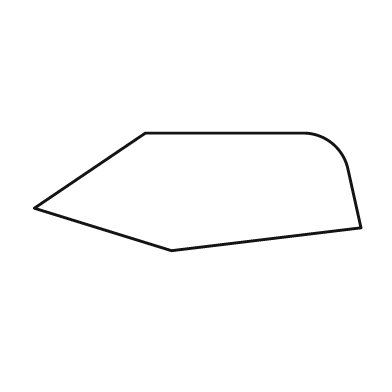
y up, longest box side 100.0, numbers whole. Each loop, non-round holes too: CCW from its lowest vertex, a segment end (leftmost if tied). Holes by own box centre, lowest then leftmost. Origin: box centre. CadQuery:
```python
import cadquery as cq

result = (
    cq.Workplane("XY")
    .moveTo(-8.0, -18.0)
    .lineTo(50.0, -11.0)
    .lineTo(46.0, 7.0)
    .threePointArc((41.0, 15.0), (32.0, 18.0))
    .lineTo(-16.0, 18.0)
    .lineTo(-50.0, -5.0)
    .close()
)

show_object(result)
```